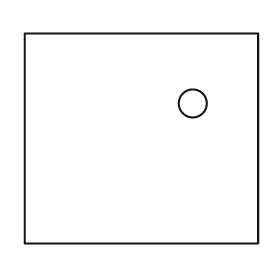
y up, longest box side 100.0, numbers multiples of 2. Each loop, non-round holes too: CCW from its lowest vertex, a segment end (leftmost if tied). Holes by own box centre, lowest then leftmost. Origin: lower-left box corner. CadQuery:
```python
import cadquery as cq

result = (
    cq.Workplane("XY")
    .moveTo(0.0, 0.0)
    .lineTo(100.0, 0.0)
    .lineTo(100.0, 90.0)
    .lineTo(0.0, 90.0)
    .close()
    .moveTo(72.0, 60.0)
    .circle(6.0)
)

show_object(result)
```